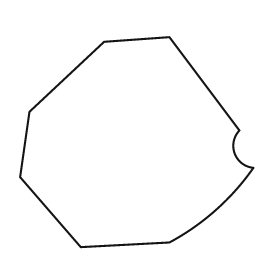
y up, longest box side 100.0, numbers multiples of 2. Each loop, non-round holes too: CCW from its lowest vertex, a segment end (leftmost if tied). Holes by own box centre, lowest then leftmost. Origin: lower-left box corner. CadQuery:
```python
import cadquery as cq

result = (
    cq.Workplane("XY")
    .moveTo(26.0, 0.0)
    .lineTo(64.0, 2.0)
    .threePointArc((84.0, 16.0), (100.0, 34.0))
    .threePointArc((92.0, 40.0), (94.0, 50.0))
    .lineTo(64.0, 90.0)
    .lineTo(36.0, 88.0)
    .lineTo(4.0, 58.0)
    .lineTo(0.0, 30.0)
    .close()
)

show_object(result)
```